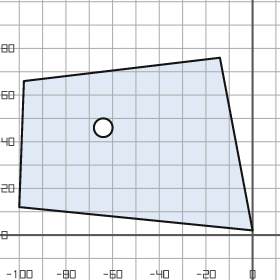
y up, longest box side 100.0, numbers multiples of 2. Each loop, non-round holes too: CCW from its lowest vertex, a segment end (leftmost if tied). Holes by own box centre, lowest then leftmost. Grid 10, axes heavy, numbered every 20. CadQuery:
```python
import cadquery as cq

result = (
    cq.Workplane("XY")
    .moveTo(0.0, 2.0)
    .lineTo(-14.0, 76.0)
    .lineTo(-98.0, 66.0)
    .lineTo(-100.0, 12.0)
    .close()
    .moveTo(-64.0, 46.0)
    .circle(4.0)
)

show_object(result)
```